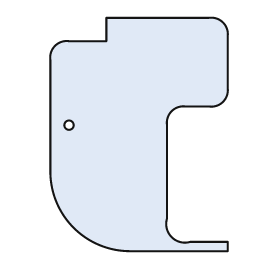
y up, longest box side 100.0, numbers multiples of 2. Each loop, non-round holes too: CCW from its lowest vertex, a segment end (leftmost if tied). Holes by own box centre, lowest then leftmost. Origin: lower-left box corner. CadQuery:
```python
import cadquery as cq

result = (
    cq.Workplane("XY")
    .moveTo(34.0, 0.0)
    .lineTo(76.0, 0.0)
    .lineTo(76.0, 4.0)
    .lineTo(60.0, 4.0)
    .threePointArc((52.0, 6.0), (50.0, 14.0))
    .lineTo(50.0, 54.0)
    .threePointArc((52.0, 60.0), (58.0, 62.0))
    .lineTo(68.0, 62.0)
    .threePointArc((74.0, 64.0), (76.0, 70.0))
    .lineTo(76.0, 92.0)
    .threePointArc((74.0, 98.0), (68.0, 100.0))
    .lineTo(24.0, 100.0)
    .lineTo(24.0, 90.0)
    .lineTo(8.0, 90.0)
    .threePointArc((2.0, 88.0), (0.0, 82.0))
    .lineTo(0.0, 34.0)
    .threePointArc((10.0, 10.0), (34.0, 0.0))
    .close()
    .moveTo(8.0, 54.0)
    .circle(2.0)
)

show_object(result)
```